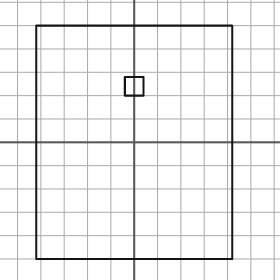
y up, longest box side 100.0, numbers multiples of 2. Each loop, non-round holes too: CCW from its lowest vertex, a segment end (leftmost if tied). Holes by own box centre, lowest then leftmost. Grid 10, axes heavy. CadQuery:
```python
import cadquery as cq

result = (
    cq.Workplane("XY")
    .moveTo(-42.0, -50.0)
    .lineTo(42.0, -50.0)
    .lineTo(42.0, 50.0)
    .lineTo(-42.0, 50.0)
    .close()
    .moveTo(-4.0, 20.0)
    .lineTo(4.0, 20.0)
    .lineTo(4.0, 28.0)
    .lineTo(-4.0, 28.0)
    .close()
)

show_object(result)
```